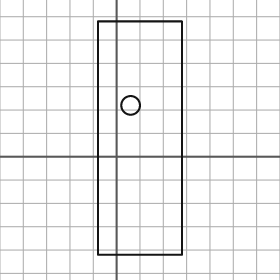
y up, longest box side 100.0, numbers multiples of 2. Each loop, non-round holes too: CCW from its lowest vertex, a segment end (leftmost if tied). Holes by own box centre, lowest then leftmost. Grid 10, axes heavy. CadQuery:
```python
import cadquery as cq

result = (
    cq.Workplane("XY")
    .moveTo(-8.0, -42.0)
    .lineTo(28.0, -42.0)
    .lineTo(28.0, 58.0)
    .lineTo(-8.0, 58.0)
    .close()
    .moveTo(6.0, 22.0)
    .circle(4.0)
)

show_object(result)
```